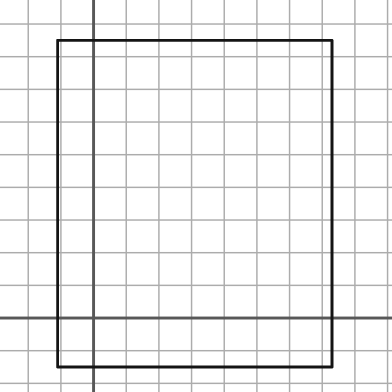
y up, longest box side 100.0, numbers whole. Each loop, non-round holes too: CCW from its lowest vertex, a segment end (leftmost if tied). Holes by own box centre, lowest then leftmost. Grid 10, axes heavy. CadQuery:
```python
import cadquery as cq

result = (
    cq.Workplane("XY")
    .moveTo(-11.0, -15.0)
    .lineTo(73.0, -15.0)
    .lineTo(73.0, 85.0)
    .lineTo(-11.0, 85.0)
    .close()
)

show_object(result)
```